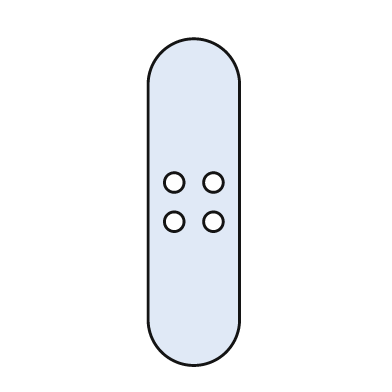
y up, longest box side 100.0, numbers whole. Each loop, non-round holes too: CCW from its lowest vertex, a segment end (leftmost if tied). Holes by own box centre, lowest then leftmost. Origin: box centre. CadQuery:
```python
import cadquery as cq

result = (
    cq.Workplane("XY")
    .moveTo(-14.0, -36.0)
    .threePointArc((0.0, -50.0), (14.0, -36.0))
    .lineTo(14.0, 36.0)
    .threePointArc((0.0, 50.0), (-14.0, 36.0))
    .close()
    .moveTo(-6.0, -6.0)
    .circle(3.0)
    .moveTo(6.0, -6.0)
    .circle(3.0)
    .moveTo(-6.0, 6.0)
    .circle(3.0)
    .moveTo(6.0, 6.0)
    .circle(3.0)
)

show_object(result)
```